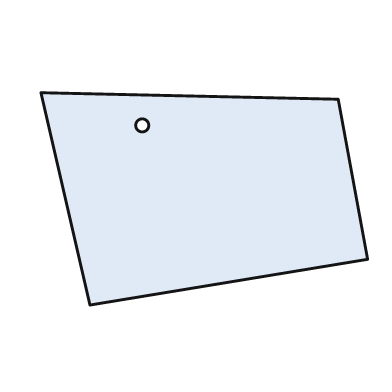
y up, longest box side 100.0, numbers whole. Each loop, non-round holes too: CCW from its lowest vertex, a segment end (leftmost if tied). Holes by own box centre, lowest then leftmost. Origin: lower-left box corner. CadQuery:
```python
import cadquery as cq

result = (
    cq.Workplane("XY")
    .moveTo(15.0, 0.0)
    .lineTo(100.0, 14.0)
    .lineTo(91.0, 63.0)
    .lineTo(0.0, 65.0)
    .close()
    .moveTo(31.0, 55.0)
    .circle(2.0)
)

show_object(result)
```